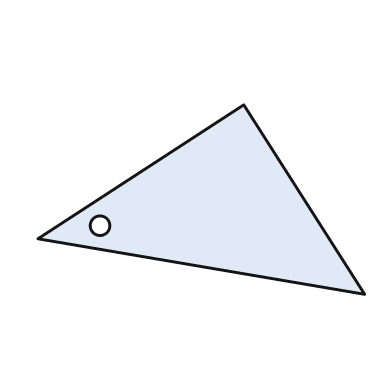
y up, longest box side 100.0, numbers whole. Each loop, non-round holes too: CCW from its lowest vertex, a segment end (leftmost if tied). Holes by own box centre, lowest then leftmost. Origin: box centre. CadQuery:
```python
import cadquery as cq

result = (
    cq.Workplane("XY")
    .moveTo(50.0, -29.0)
    .lineTo(13.0, 29.0)
    .lineTo(-50.0, -12.0)
    .close()
    .moveTo(-31.0, -8.0)
    .circle(3.0)
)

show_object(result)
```